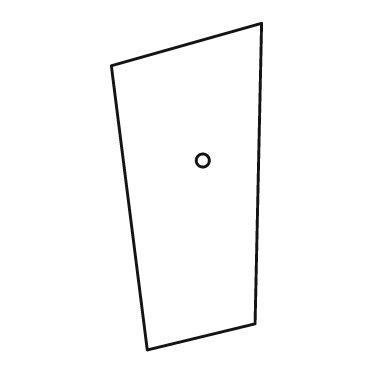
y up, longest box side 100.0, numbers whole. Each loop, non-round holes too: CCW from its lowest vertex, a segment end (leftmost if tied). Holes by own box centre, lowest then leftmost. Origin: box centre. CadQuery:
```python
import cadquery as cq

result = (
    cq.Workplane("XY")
    .moveTo(-12.0, -50.0)
    .lineTo(21.0, -42.0)
    .lineTo(23.0, 50.0)
    .lineTo(-23.0, 37.0)
    .close()
    .moveTo(5.0, 8.0)
    .circle(2.0)
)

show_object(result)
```